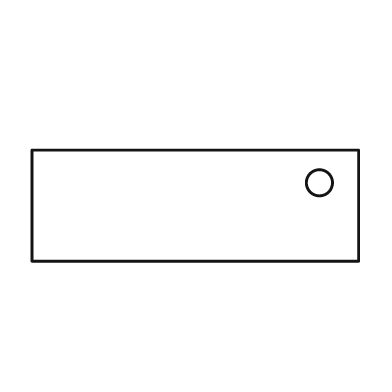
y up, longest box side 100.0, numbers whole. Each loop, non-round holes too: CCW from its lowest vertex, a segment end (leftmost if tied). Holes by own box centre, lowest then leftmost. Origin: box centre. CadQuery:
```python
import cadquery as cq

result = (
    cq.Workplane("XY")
    .moveTo(-50.0, -17.0)
    .lineTo(50.0, -17.0)
    .lineTo(50.0, 17.0)
    .lineTo(-50.0, 17.0)
    .close()
    .moveTo(38.0, 7.0)
    .circle(4.0)
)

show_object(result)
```